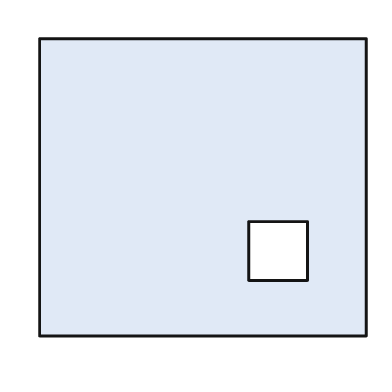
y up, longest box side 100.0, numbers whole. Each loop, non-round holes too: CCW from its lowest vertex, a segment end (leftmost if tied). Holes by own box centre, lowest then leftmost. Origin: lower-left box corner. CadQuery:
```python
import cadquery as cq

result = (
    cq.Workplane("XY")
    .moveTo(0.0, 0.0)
    .lineTo(100.0, 0.0)
    .lineTo(100.0, 91.0)
    .lineTo(0.0, 91.0)
    .close()
    .moveTo(64.0, 17.0)
    .lineTo(82.0, 17.0)
    .lineTo(82.0, 35.0)
    .lineTo(64.0, 35.0)
    .close()
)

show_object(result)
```